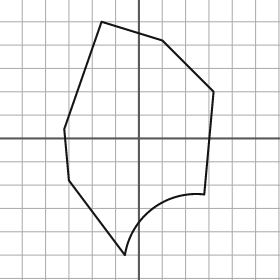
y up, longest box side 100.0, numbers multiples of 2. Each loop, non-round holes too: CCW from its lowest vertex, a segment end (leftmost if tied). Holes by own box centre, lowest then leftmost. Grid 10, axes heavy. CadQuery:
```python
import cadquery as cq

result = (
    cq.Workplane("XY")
    .moveTo(-6.0, -50.0)
    .threePointArc((6.0, -30.0), (28.0, -24.0))
    .lineTo(32.0, 20.0)
    .lineTo(10.0, 42.0)
    .lineTo(-16.0, 50.0)
    .lineTo(-32.0, 4.0)
    .lineTo(-30.0, -18.0)
    .close()
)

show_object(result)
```